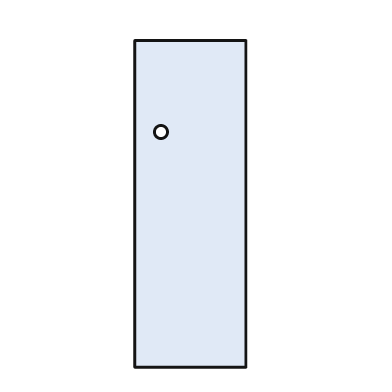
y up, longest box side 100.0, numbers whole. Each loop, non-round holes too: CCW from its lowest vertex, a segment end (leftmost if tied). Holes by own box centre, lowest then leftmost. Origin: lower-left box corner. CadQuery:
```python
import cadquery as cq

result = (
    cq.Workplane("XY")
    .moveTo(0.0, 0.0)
    .lineTo(34.0, 0.0)
    .lineTo(34.0, 100.0)
    .lineTo(0.0, 100.0)
    .close()
    .moveTo(8.0, 72.0)
    .circle(2.0)
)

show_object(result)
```